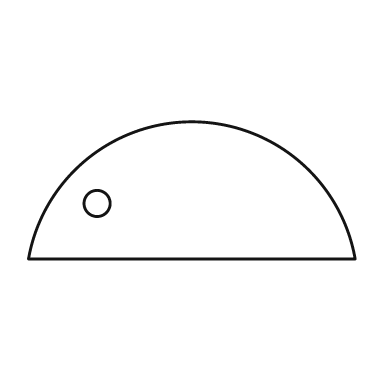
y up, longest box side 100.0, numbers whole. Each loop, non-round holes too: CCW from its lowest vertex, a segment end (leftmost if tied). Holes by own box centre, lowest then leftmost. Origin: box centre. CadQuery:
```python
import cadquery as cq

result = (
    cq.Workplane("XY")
    .moveTo(-50.0, -21.0)
    .lineTo(50.0, -21.0)
    .threePointArc((0.0, 21.0), (-50.0, -21.0))
    .close()
    .moveTo(-29.0, -4.0)
    .circle(4.0)
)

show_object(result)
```